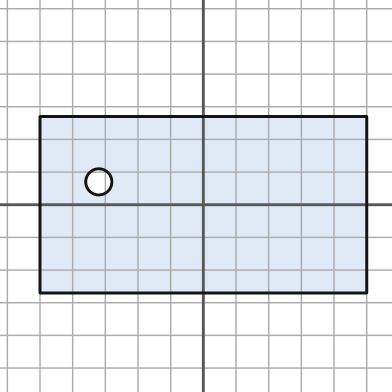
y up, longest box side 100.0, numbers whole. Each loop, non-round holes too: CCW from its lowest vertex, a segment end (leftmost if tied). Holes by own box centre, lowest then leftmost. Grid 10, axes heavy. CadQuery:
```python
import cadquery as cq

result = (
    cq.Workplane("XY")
    .moveTo(-50.0, -27.0)
    .lineTo(50.0, -27.0)
    .lineTo(50.0, 27.0)
    .lineTo(-50.0, 27.0)
    .close()
    .moveTo(-32.0, 7.0)
    .circle(4.0)
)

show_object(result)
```